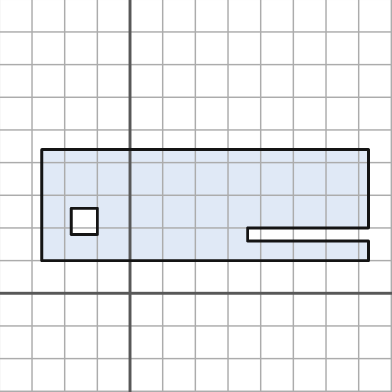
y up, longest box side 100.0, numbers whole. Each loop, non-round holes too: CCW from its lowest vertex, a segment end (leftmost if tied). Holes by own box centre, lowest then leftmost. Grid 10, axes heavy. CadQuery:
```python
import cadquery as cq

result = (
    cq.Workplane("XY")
    .moveTo(-27.0, 10.0)
    .lineTo(73.0, 10.0)
    .lineTo(73.0, 16.0)
    .lineTo(36.0, 16.0)
    .lineTo(36.0, 20.0)
    .lineTo(73.0, 20.0)
    .lineTo(73.0, 44.0)
    .lineTo(-27.0, 44.0)
    .close()
    .moveTo(-18.0, 18.0)
    .lineTo(-10.0, 18.0)
    .lineTo(-10.0, 26.0)
    .lineTo(-18.0, 26.0)
    .close()
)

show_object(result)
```